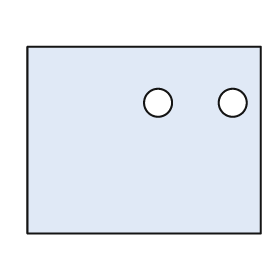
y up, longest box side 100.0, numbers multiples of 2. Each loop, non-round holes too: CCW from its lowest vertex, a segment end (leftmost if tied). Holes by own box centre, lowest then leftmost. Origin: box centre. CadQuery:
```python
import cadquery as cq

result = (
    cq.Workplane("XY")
    .moveTo(-50.0, -40.0)
    .lineTo(50.0, -40.0)
    .lineTo(50.0, 40.0)
    .lineTo(-50.0, 40.0)
    .close()
    .moveTo(6.0, 16.0)
    .circle(6.0)
    .moveTo(38.0, 16.0)
    .circle(6.0)
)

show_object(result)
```